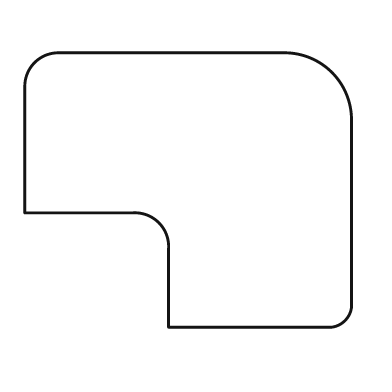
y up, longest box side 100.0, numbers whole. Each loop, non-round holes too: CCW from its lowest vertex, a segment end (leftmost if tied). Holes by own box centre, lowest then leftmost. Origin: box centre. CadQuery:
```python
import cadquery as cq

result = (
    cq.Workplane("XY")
    .moveTo(-6.0, -42.0)
    .lineTo(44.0, -42.0)
    .threePointArc((48.0, -40.0), (50.0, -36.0))
    .lineTo(50.0, 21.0)
    .threePointArc((44.0, 36.0), (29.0, 42.0))
    .lineTo(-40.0, 42.0)
    .threePointArc((-47.0, 39.0), (-50.0, 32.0))
    .lineTo(-50.0, -7.0)
    .lineTo(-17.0, -7.0)
    .threePointArc((-9.0, -10.0), (-6.0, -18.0))
    .close()
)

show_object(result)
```